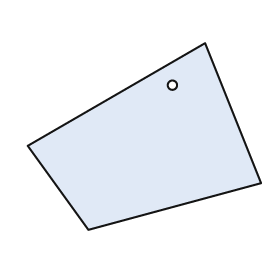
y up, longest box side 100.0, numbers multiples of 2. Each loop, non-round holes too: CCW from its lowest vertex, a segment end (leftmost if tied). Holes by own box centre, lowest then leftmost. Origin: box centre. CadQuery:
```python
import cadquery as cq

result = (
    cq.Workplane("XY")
    .moveTo(-24.0, -40.0)
    .lineTo(50.0, -20.0)
    .lineTo(26.0, 40.0)
    .lineTo(-50.0, -4.0)
    .close()
    .moveTo(12.0, 22.0)
    .circle(2.0)
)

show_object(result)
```